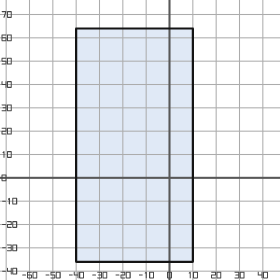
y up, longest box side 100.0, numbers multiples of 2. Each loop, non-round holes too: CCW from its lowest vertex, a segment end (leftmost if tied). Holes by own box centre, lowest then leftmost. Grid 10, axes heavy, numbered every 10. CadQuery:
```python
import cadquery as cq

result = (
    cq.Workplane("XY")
    .moveTo(-40.0, -36.0)
    .lineTo(10.0, -36.0)
    .lineTo(10.0, 64.0)
    .lineTo(-40.0, 64.0)
    .close()
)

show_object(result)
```